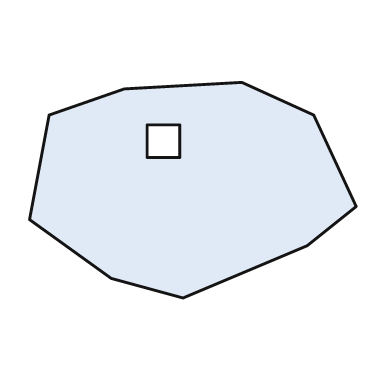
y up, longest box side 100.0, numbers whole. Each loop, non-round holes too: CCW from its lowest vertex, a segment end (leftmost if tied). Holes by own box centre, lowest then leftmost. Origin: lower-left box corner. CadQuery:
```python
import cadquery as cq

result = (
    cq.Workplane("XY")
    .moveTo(47.0, 0.0)
    .lineTo(85.0, 16.0)
    .lineTo(100.0, 28.0)
    .lineTo(87.0, 56.0)
    .lineTo(65.0, 66.0)
    .lineTo(29.0, 64.0)
    .lineTo(6.0, 56.0)
    .lineTo(0.0, 24.0)
    .lineTo(25.0, 6.0)
    .close()
    .moveTo(36.0, 43.0)
    .lineTo(46.0, 43.0)
    .lineTo(46.0, 53.0)
    .lineTo(36.0, 53.0)
    .close()
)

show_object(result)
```